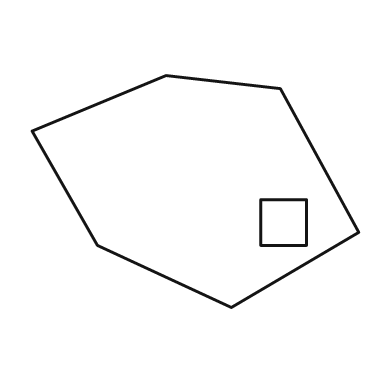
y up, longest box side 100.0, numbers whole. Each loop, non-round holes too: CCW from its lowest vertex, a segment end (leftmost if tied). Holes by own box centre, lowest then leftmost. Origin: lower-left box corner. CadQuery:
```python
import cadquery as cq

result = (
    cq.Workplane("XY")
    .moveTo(61.0, 0.0)
    .lineTo(100.0, 23.0)
    .lineTo(76.0, 67.0)
    .lineTo(41.0, 71.0)
    .lineTo(0.0, 54.0)
    .lineTo(20.0, 19.0)
    .close()
    .moveTo(70.0, 19.0)
    .lineTo(84.0, 19.0)
    .lineTo(84.0, 33.0)
    .lineTo(70.0, 33.0)
    .close()
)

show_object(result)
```